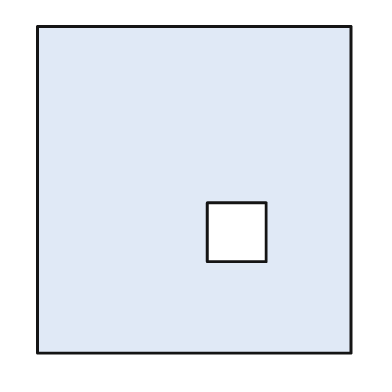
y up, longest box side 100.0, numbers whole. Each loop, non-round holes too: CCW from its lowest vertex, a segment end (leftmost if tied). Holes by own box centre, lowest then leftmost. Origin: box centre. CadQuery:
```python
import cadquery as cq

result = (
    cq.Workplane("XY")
    .moveTo(-48.0, -50.0)
    .lineTo(48.0, -50.0)
    .lineTo(48.0, 50.0)
    .lineTo(-48.0, 50.0)
    .close()
    .moveTo(4.0, -22.0)
    .lineTo(22.0, -22.0)
    .lineTo(22.0, -4.0)
    .lineTo(4.0, -4.0)
    .close()
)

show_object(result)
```